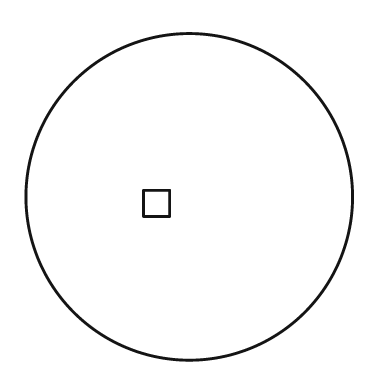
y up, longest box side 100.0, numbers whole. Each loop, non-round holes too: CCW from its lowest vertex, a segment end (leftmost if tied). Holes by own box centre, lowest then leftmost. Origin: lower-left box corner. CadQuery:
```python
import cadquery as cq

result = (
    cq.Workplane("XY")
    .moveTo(50.0, 50.0)
    .circle(50.0)
    .moveTo(36.0, 44.0)
    .lineTo(44.0, 44.0)
    .lineTo(44.0, 52.0)
    .lineTo(36.0, 52.0)
    .close()
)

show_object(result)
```